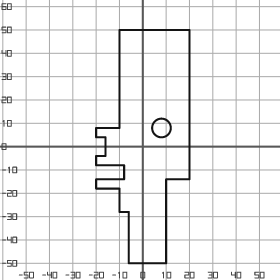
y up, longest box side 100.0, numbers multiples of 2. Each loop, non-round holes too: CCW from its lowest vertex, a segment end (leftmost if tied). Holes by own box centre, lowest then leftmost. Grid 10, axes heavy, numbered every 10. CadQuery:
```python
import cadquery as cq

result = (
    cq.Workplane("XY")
    .moveTo(-6.0, -50.0)
    .lineTo(10.0, -50.0)
    .lineTo(10.0, -14.0)
    .lineTo(20.0, -14.0)
    .lineTo(20.0, 50.0)
    .lineTo(-10.0, 50.0)
    .lineTo(-10.0, 8.0)
    .lineTo(-20.0, 8.0)
    .lineTo(-20.0, 4.0)
    .lineTo(-16.0, 4.0)
    .lineTo(-16.0, -4.0)
    .lineTo(-20.0, -4.0)
    .lineTo(-20.0, -8.0)
    .lineTo(-8.0, -8.0)
    .lineTo(-8.0, -14.0)
    .lineTo(-20.0, -14.0)
    .lineTo(-20.0, -18.0)
    .lineTo(-10.0, -18.0)
    .lineTo(-10.0, -28.0)
    .lineTo(-6.0, -28.0)
    .close()
    .moveTo(8.0, 8.0)
    .circle(4.0)
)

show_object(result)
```